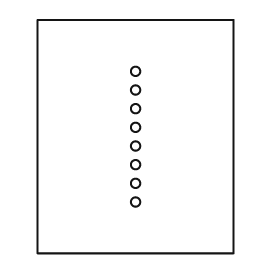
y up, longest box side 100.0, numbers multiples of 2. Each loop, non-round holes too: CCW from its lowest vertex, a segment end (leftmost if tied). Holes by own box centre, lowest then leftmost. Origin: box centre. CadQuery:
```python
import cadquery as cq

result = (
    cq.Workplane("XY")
    .moveTo(-42.0, -50.0)
    .lineTo(42.0, -50.0)
    .lineTo(42.0, 50.0)
    .lineTo(-42.0, 50.0)
    .close()
    .moveTo(0.0, -28.0)
    .circle(2.0)
    .moveTo(0.0, -20.0)
    .circle(2.0)
    .moveTo(0.0, -12.0)
    .circle(2.0)
    .moveTo(0.0, -4.0)
    .circle(2.0)
    .moveTo(0.0, 4.0)
    .circle(2.0)
    .moveTo(0.0, 12.0)
    .circle(2.0)
    .moveTo(0.0, 20.0)
    .circle(2.0)
    .moveTo(0.0, 28.0)
    .circle(2.0)
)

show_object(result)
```